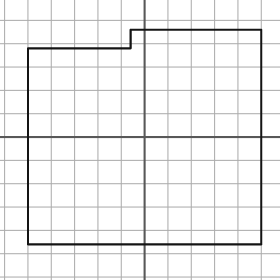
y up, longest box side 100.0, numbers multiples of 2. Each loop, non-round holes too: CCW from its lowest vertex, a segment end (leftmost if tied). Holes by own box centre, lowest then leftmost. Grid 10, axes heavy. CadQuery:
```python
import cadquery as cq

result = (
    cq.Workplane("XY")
    .moveTo(-50.0, -46.0)
    .lineTo(50.0, -46.0)
    .lineTo(50.0, 46.0)
    .lineTo(-6.0, 46.0)
    .lineTo(-6.0, 38.0)
    .lineTo(-50.0, 38.0)
    .close()
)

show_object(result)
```